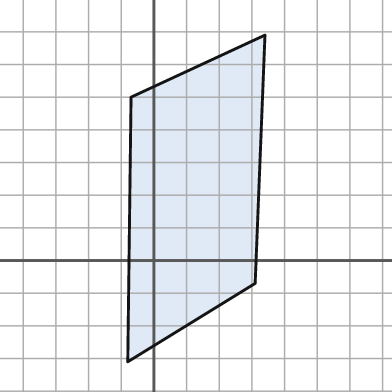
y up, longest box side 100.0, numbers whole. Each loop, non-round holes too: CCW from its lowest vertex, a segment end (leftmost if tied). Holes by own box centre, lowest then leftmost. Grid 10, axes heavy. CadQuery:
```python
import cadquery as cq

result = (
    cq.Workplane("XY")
    .moveTo(-8.0, -31.0)
    .lineTo(31.0, -7.0)
    .lineTo(34.0, 69.0)
    .lineTo(-7.0, 50.0)
    .close()
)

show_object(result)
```